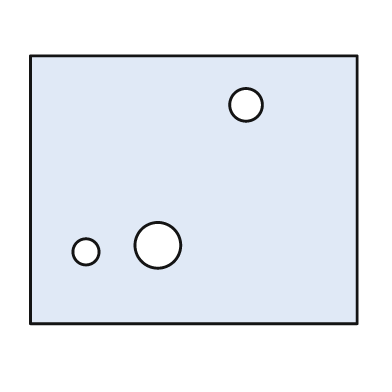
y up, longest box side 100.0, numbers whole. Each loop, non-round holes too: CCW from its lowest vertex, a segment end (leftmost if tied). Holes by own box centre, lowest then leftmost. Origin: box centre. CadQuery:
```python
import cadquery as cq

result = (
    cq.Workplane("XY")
    .moveTo(-50.0, -41.0)
    .lineTo(50.0, -41.0)
    .lineTo(50.0, 41.0)
    .lineTo(-50.0, 41.0)
    .close()
    .moveTo(-33.0, -19.0)
    .circle(4.0)
    .moveTo(-11.0, -17.0)
    .circle(7.0)
    .moveTo(16.0, 26.0)
    .circle(5.0)
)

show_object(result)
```